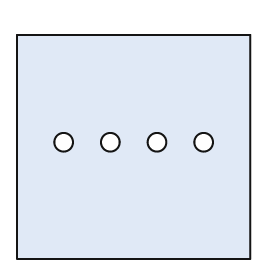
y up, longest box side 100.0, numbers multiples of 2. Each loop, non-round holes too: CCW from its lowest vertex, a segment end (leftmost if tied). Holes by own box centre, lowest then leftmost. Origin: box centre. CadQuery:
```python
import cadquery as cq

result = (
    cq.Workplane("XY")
    .moveTo(-50.0, -48.0)
    .lineTo(50.0, -48.0)
    .lineTo(50.0, 48.0)
    .lineTo(-50.0, 48.0)
    .close()
    .moveTo(-30.0, 2.0)
    .circle(4.0)
    .moveTo(-10.0, 2.0)
    .circle(4.0)
    .moveTo(10.0, 2.0)
    .circle(4.0)
    .moveTo(30.0, 2.0)
    .circle(4.0)
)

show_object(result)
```